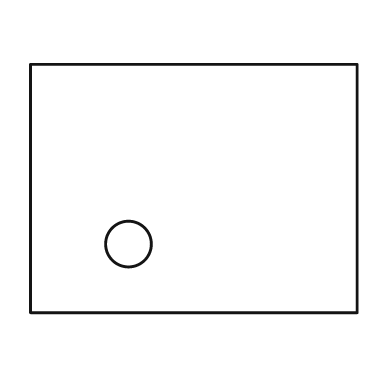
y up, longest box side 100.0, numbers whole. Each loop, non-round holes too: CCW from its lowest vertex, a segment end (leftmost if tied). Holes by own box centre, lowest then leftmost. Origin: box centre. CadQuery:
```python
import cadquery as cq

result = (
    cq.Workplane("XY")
    .moveTo(-50.0, -38.0)
    .lineTo(50.0, -38.0)
    .lineTo(50.0, 38.0)
    .lineTo(-50.0, 38.0)
    .close()
    .moveTo(-20.0, -17.0)
    .circle(7.0)
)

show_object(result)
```